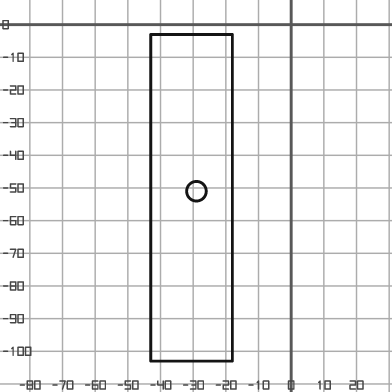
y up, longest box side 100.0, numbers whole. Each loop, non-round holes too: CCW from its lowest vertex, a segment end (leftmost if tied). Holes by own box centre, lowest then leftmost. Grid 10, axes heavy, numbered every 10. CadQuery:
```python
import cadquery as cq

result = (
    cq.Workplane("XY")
    .moveTo(-43.0, -103.0)
    .lineTo(-18.0, -103.0)
    .lineTo(-18.0, -3.0)
    .lineTo(-43.0, -3.0)
    .close()
    .moveTo(-29.0, -51.0)
    .circle(3.0)
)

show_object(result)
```